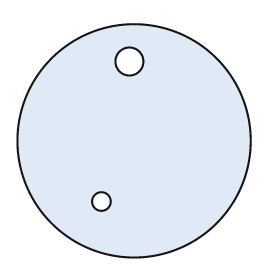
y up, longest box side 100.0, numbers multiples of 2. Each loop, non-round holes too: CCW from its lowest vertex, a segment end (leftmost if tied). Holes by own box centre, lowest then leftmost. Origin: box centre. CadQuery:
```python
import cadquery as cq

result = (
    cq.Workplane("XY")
    .moveTo(0.0, 0.0)
    .circle(50.0)
    .moveTo(-14.0, -26.0)
    .circle(4.0)
    .moveTo(-2.0, 34.0)
    .circle(6.0)
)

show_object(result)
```